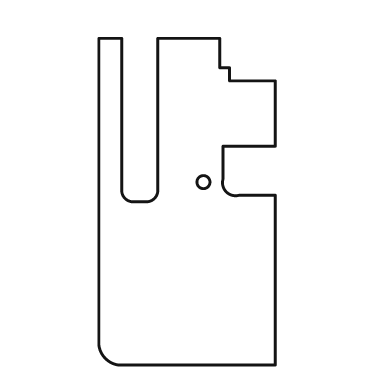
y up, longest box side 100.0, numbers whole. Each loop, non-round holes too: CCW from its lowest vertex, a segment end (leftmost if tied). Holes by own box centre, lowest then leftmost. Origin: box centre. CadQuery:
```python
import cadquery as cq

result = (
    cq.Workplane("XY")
    .moveTo(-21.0, -50.0)
    .lineTo(27.0, -50.0)
    .lineTo(27.0, 2.0)
    .lineTo(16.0, 2.0)
    .threePointArc((12.0, 3.0), (11.0, 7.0))
    .lineTo(11.0, 17.0)
    .lineTo(27.0, 17.0)
    .lineTo(27.0, 37.0)
    .lineTo(13.0, 37.0)
    .lineTo(13.0, 41.0)
    .lineTo(10.0, 41.0)
    .lineTo(10.0, 50.0)
    .lineTo(-9.0, 50.0)
    .lineTo(-9.0, 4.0)
    .threePointArc((-10.0, 1.0), (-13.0, 0.0))
    .lineTo(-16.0, 0.0)
    .threePointArc((-19.0, 1.0), (-20.0, 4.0))
    .lineTo(-20.0, 50.0)
    .lineTo(-27.0, 50.0)
    .lineTo(-27.0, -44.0)
    .threePointArc((-25.0, -48.0), (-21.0, -50.0))
    .close()
    .moveTo(5.0, 6.0)
    .circle(2.0)
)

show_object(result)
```